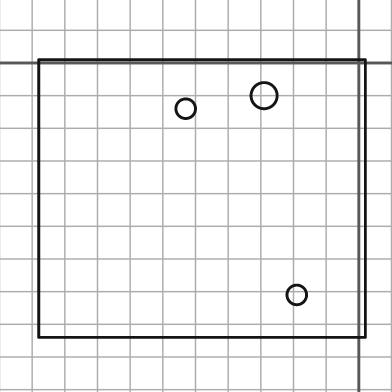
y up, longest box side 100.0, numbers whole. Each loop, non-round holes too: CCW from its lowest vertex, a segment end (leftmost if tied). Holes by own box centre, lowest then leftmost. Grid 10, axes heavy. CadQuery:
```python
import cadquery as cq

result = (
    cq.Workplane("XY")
    .moveTo(-98.0, -84.0)
    .lineTo(2.0, -84.0)
    .lineTo(2.0, 1.0)
    .lineTo(-98.0, 1.0)
    .close()
    .moveTo(-19.0, -71.0)
    .circle(3.0)
    .moveTo(-53.0, -14.0)
    .circle(3.0)
    .moveTo(-29.0, -10.0)
    .circle(4.0)
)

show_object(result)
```